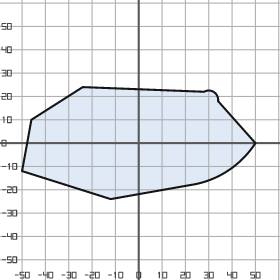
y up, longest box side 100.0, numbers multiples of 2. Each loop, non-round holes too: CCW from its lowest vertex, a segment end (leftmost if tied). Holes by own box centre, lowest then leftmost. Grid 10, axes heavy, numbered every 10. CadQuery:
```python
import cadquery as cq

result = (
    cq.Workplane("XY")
    .moveTo(-12.0, -24.0)
    .lineTo(22.0, -18.0)
    .threePointArc((38.0, -12.0), (50.0, 0.0))
    .lineTo(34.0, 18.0)
    .threePointArc((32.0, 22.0), (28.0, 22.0))
    .lineTo(-24.0, 24.0)
    .lineTo(-46.0, 10.0)
    .lineTo(-50.0, -12.0)
    .close()
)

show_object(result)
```